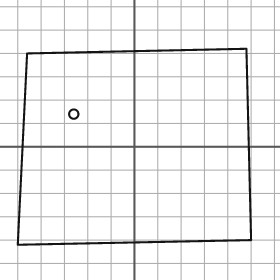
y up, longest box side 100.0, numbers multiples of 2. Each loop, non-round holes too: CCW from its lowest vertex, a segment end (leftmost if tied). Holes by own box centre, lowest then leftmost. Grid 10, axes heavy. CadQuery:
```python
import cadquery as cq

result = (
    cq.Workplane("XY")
    .moveTo(-50.0, -42.0)
    .lineTo(50.0, -40.0)
    .lineTo(48.0, 42.0)
    .lineTo(-46.0, 40.0)
    .close()
    .moveTo(-26.0, 14.0)
    .circle(2.0)
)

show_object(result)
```